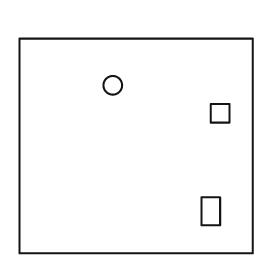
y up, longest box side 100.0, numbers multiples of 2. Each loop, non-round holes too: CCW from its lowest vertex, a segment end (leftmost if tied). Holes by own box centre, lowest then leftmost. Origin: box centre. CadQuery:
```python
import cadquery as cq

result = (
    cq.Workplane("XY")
    .moveTo(-50.0, -46.0)
    .lineTo(50.0, -46.0)
    .lineTo(50.0, 46.0)
    .lineTo(-50.0, 46.0)
    .close()
    .moveTo(28.0, -34.0)
    .lineTo(36.0, -34.0)
    .lineTo(36.0, -22.0)
    .lineTo(28.0, -22.0)
    .close()
    .moveTo(32.0, 10.0)
    .lineTo(40.0, 10.0)
    .lineTo(40.0, 18.0)
    .lineTo(32.0, 18.0)
    .close()
    .moveTo(-10.0, 26.0)
    .circle(4.0)
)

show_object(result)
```